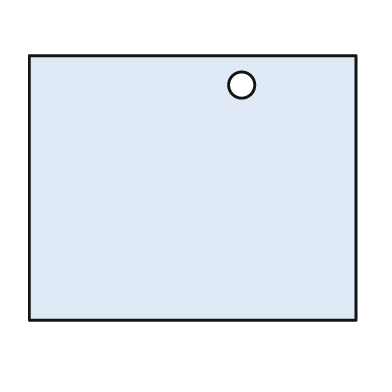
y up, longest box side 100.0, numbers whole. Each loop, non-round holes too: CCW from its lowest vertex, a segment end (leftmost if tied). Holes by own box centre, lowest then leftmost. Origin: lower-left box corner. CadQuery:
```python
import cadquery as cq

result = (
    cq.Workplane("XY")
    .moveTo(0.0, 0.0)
    .lineTo(100.0, 0.0)
    .lineTo(100.0, 81.0)
    .lineTo(0.0, 81.0)
    .close()
    .moveTo(65.0, 72.0)
    .circle(4.0)
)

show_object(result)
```